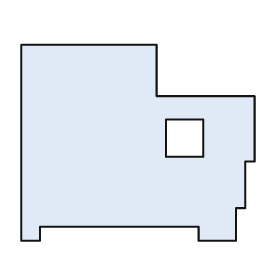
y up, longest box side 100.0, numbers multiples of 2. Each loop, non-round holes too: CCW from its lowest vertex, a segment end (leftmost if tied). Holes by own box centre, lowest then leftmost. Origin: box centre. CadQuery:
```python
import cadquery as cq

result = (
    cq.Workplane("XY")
    .moveTo(-50.0, -42.0)
    .lineTo(-42.0, -42.0)
    .lineTo(-42.0, -36.0)
    .lineTo(26.0, -36.0)
    .lineTo(26.0, -42.0)
    .lineTo(42.0, -42.0)
    .lineTo(42.0, -28.0)
    .lineTo(46.0, -28.0)
    .lineTo(46.0, -8.0)
    .lineTo(50.0, -8.0)
    .lineTo(50.0, 20.0)
    .lineTo(8.0, 20.0)
    .lineTo(8.0, 42.0)
    .lineTo(-50.0, 42.0)
    .close()
    .moveTo(12.0, -6.0)
    .lineTo(28.0, -6.0)
    .lineTo(28.0, 10.0)
    .lineTo(12.0, 10.0)
    .close()
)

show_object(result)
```